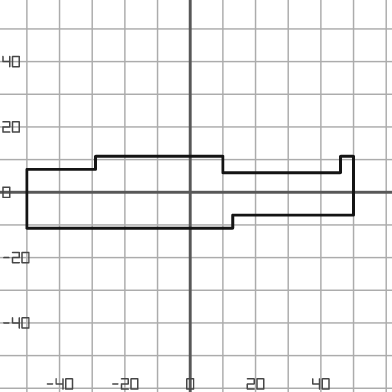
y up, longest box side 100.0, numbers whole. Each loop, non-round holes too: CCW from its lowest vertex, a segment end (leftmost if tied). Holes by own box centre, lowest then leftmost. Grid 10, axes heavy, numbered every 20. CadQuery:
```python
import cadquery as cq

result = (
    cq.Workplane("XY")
    .moveTo(-50.0, -11.0)
    .lineTo(13.0, -11.0)
    .lineTo(13.0, -7.0)
    .lineTo(50.0, -7.0)
    .lineTo(50.0, 11.0)
    .lineTo(46.0, 11.0)
    .lineTo(46.0, 6.0)
    .lineTo(10.0, 6.0)
    .lineTo(10.0, 11.0)
    .lineTo(-29.0, 11.0)
    .lineTo(-29.0, 7.0)
    .lineTo(-50.0, 7.0)
    .close()
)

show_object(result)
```